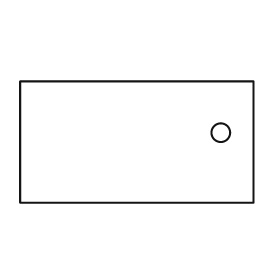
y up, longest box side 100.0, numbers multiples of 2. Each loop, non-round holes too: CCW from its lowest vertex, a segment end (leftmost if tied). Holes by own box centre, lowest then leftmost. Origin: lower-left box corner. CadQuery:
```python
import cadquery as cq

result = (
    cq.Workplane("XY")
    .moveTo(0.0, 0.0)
    .lineTo(100.0, 0.0)
    .lineTo(100.0, 52.0)
    .lineTo(0.0, 52.0)
    .close()
    .moveTo(86.0, 30.0)
    .circle(4.0)
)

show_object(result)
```